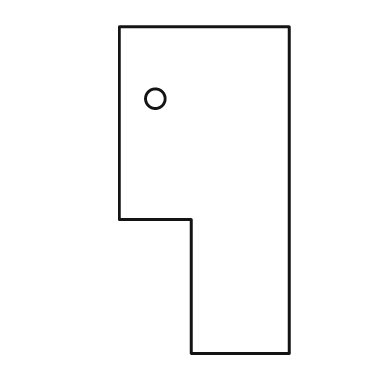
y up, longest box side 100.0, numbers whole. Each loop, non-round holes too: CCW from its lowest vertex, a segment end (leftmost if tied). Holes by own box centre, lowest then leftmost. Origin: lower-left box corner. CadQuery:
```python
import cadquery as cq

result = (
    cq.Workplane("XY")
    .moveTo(22.0, 0.0)
    .lineTo(52.0, 0.0)
    .lineTo(52.0, 100.0)
    .lineTo(0.0, 100.0)
    .lineTo(0.0, 41.0)
    .lineTo(22.0, 41.0)
    .close()
    .moveTo(11.0, 78.0)
    .circle(3.0)
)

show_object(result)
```